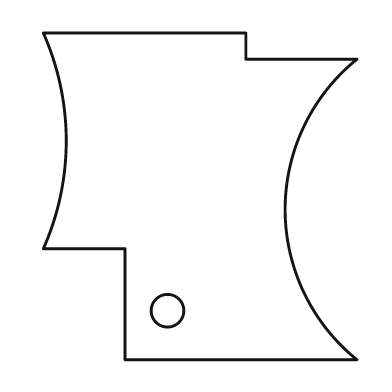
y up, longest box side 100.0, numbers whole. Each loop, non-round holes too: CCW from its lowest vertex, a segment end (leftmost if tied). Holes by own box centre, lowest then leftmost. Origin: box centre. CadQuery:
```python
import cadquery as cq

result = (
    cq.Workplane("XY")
    .moveTo(-23.0, -50.0)
    .lineTo(48.0, -50.0)
    .threePointArc((26.0, -4.0), (48.0, 42.0))
    .lineTo(14.0, 42.0)
    .lineTo(14.0, 50.0)
    .lineTo(-48.0, 50.0)
    .threePointArc((-41.0, 17.0), (-48.0, -16.0))
    .lineTo(-23.0, -16.0)
    .close()
    .moveTo(-10.0, -35.0)
    .circle(5.0)
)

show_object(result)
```